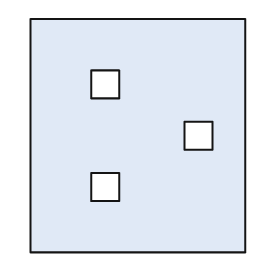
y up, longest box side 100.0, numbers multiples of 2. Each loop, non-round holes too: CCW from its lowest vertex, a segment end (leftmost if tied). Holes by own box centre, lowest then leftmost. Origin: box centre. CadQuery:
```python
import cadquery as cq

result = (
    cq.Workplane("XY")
    .moveTo(-46.0, -50.0)
    .lineTo(46.0, -50.0)
    .lineTo(46.0, 50.0)
    .lineTo(-46.0, 50.0)
    .close()
    .moveTo(-20.0, -28.0)
    .lineTo(-8.0, -28.0)
    .lineTo(-8.0, -16.0)
    .lineTo(-20.0, -16.0)
    .close()
    .moveTo(20.0, -6.0)
    .lineTo(32.0, -6.0)
    .lineTo(32.0, 6.0)
    .lineTo(20.0, 6.0)
    .close()
    .moveTo(-20.0, 16.0)
    .lineTo(-8.0, 16.0)
    .lineTo(-8.0, 28.0)
    .lineTo(-20.0, 28.0)
    .close()
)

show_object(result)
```